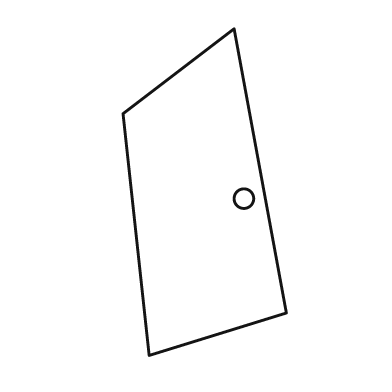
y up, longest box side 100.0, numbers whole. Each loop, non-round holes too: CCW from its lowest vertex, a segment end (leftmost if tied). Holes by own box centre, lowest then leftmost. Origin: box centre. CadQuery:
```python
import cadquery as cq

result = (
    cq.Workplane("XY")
    .moveTo(-17.0, -50.0)
    .lineTo(25.0, -37.0)
    .lineTo(9.0, 50.0)
    .lineTo(-25.0, 24.0)
    .close()
    .moveTo(12.0, -2.0)
    .circle(3.0)
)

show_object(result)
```